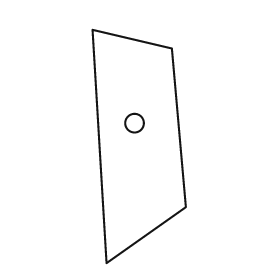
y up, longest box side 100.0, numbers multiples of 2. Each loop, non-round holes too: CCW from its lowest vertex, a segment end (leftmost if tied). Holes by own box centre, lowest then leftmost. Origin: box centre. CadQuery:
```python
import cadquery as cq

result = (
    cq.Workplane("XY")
    .moveTo(-14.0, -50.0)
    .lineTo(20.0, -26.0)
    .lineTo(14.0, 42.0)
    .lineTo(-20.0, 50.0)
    .close()
    .moveTo(-2.0, 10.0)
    .circle(4.0)
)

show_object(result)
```